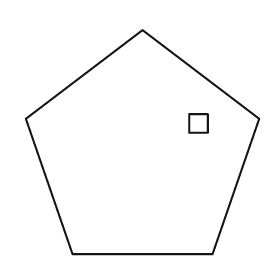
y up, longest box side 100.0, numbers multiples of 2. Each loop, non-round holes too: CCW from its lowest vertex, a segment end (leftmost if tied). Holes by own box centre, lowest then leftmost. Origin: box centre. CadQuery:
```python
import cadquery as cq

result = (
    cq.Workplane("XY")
    .moveTo(-30.0, -48.0)
    .lineTo(30.0, -48.0)
    .lineTo(50.0, 10.0)
    .lineTo(0.0, 48.0)
    .lineTo(-50.0, 10.0)
    .close()
    .moveTo(20.0, 4.0)
    .lineTo(28.0, 4.0)
    .lineTo(28.0, 12.0)
    .lineTo(20.0, 12.0)
    .close()
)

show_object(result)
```